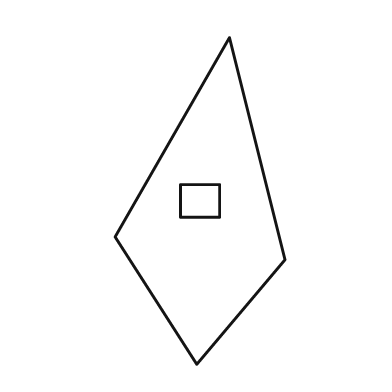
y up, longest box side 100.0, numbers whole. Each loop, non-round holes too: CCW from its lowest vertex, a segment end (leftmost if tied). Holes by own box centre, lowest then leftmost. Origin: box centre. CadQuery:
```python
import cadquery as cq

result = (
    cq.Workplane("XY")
    .moveTo(-1.0, -50.0)
    .lineTo(26.0, -18.0)
    .lineTo(9.0, 50.0)
    .lineTo(-26.0, -11.0)
    .close()
    .moveTo(-6.0, -5.0)
    .lineTo(6.0, -5.0)
    .lineTo(6.0, 5.0)
    .lineTo(-6.0, 5.0)
    .close()
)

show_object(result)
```